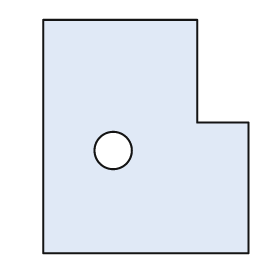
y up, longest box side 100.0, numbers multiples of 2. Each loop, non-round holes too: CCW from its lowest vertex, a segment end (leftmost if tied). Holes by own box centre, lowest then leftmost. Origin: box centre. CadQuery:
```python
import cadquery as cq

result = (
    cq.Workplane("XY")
    .moveTo(-44.0, -50.0)
    .lineTo(44.0, -50.0)
    .lineTo(44.0, 6.0)
    .lineTo(22.0, 6.0)
    .lineTo(22.0, 50.0)
    .lineTo(-44.0, 50.0)
    .close()
    .moveTo(-14.0, -6.0)
    .circle(8.0)
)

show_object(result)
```